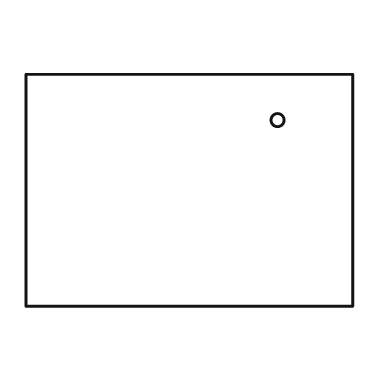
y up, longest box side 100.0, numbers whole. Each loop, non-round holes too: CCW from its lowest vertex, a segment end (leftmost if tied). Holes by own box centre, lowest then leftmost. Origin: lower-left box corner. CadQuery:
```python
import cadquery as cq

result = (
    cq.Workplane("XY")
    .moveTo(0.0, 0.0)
    .lineTo(100.0, 0.0)
    .lineTo(100.0, 71.0)
    .lineTo(0.0, 71.0)
    .close()
    .moveTo(77.0, 57.0)
    .circle(2.0)
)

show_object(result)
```